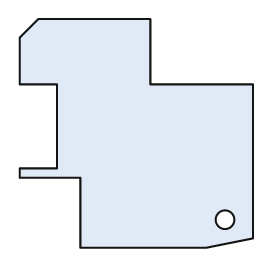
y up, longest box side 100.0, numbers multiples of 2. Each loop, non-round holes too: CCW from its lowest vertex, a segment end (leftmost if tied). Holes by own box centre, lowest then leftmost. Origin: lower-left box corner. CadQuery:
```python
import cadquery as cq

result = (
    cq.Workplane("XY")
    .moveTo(26.0, 0.0)
    .lineTo(80.0, 0.0)
    .lineTo(100.0, 4.0)
    .lineTo(100.0, 70.0)
    .lineTo(56.0, 70.0)
    .lineTo(56.0, 98.0)
    .lineTo(8.0, 98.0)
    .lineTo(0.0, 90.0)
    .lineTo(0.0, 70.0)
    .lineTo(16.0, 70.0)
    .lineTo(16.0, 34.0)
    .lineTo(0.0, 34.0)
    .lineTo(0.0, 30.0)
    .lineTo(26.0, 30.0)
    .close()
    .moveTo(88.0, 12.0)
    .circle(4.0)
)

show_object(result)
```